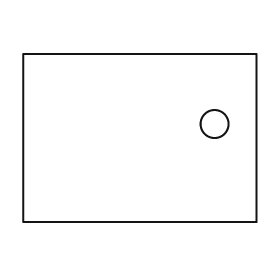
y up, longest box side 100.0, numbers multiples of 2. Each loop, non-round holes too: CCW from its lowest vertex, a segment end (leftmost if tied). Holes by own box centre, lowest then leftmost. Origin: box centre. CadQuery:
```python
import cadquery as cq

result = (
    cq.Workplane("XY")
    .moveTo(-50.0, -36.0)
    .lineTo(50.0, -36.0)
    .lineTo(50.0, 36.0)
    .lineTo(-50.0, 36.0)
    .close()
    .moveTo(32.0, 6.0)
    .circle(6.0)
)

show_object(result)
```